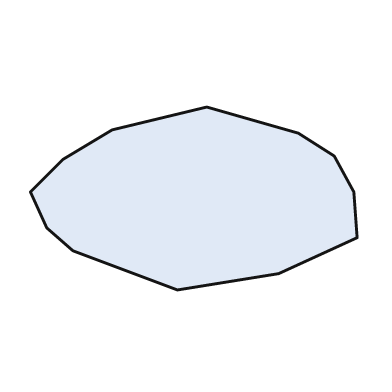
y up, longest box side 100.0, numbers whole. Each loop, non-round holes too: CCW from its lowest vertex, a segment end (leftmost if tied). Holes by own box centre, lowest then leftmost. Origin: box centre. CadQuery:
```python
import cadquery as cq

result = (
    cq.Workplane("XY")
    .moveTo(-5.0, -28.0)
    .lineTo(26.0, -23.0)
    .lineTo(50.0, -12.0)
    .lineTo(49.0, 2.0)
    .lineTo(43.0, 13.0)
    .lineTo(32.0, 20.0)
    .lineTo(4.0, 28.0)
    .lineTo(-25.0, 21.0)
    .lineTo(-40.0, 12.0)
    .lineTo(-50.0, 2.0)
    .lineTo(-45.0, -9.0)
    .lineTo(-37.0, -16.0)
    .close()
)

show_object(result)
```